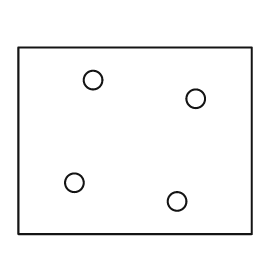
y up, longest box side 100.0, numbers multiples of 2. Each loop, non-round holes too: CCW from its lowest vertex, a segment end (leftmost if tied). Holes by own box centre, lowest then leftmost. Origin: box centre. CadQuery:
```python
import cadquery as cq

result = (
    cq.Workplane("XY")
    .moveTo(-50.0, -40.0)
    .lineTo(50.0, -40.0)
    .lineTo(50.0, 40.0)
    .lineTo(-50.0, 40.0)
    .close()
    .moveTo(18.0, -26.0)
    .circle(4.0)
    .moveTo(-26.0, -18.0)
    .circle(4.0)
    .moveTo(26.0, 18.0)
    .circle(4.0)
    .moveTo(-18.0, 26.0)
    .circle(4.0)
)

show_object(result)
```